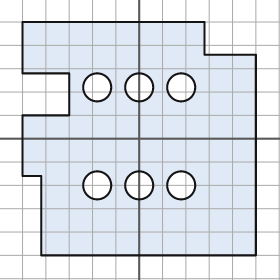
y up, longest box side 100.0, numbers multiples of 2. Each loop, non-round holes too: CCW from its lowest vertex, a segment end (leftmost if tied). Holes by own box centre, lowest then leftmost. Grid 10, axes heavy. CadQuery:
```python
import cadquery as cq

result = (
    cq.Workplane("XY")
    .moveTo(-42.0, -50.0)
    .lineTo(50.0, -50.0)
    .lineTo(50.0, 36.0)
    .lineTo(28.0, 36.0)
    .lineTo(28.0, 50.0)
    .lineTo(-50.0, 50.0)
    .lineTo(-50.0, 28.0)
    .lineTo(-30.0, 28.0)
    .lineTo(-30.0, 10.0)
    .lineTo(-50.0, 10.0)
    .lineTo(-50.0, -16.0)
    .lineTo(-42.0, -16.0)
    .close()
    .moveTo(-18.0, -20.0)
    .circle(6.0)
    .moveTo(0.0, -20.0)
    .circle(6.0)
    .moveTo(18.0, -20.0)
    .circle(6.0)
    .moveTo(-18.0, 22.0)
    .circle(6.0)
    .moveTo(0.0, 22.0)
    .circle(6.0)
    .moveTo(18.0, 22.0)
    .circle(6.0)
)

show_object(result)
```